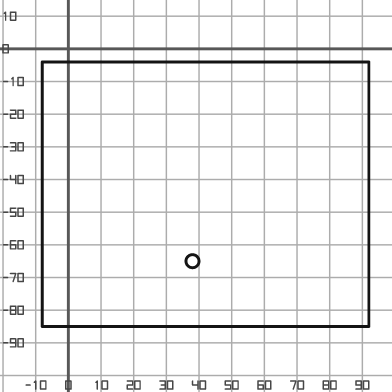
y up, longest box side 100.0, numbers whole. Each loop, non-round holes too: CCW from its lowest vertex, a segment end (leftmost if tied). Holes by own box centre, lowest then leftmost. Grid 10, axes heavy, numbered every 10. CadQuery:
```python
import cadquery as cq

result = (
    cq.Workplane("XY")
    .moveTo(-8.0, -85.0)
    .lineTo(92.0, -85.0)
    .lineTo(92.0, -4.0)
    .lineTo(-8.0, -4.0)
    .close()
    .moveTo(38.0, -65.0)
    .circle(2.0)
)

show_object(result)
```